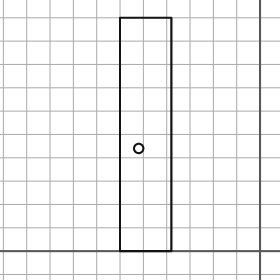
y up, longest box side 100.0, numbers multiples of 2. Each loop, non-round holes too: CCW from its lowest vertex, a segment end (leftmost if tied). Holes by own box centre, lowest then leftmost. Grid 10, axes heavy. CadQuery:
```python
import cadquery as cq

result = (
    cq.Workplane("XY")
    .moveTo(-60.0, 0.0)
    .lineTo(-38.0, 0.0)
    .lineTo(-38.0, 100.0)
    .lineTo(-60.0, 100.0)
    .close()
    .moveTo(-52.0, 44.0)
    .circle(2.0)
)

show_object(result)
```